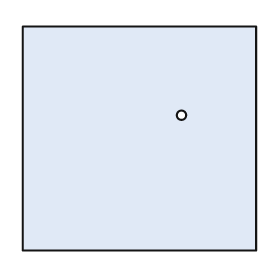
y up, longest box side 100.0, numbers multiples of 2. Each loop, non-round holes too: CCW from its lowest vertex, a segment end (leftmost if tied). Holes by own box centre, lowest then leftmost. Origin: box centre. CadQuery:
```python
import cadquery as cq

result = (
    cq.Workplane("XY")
    .moveTo(-50.0, -48.0)
    .lineTo(50.0, -48.0)
    .lineTo(50.0, 48.0)
    .lineTo(-50.0, 48.0)
    .close()
    .moveTo(18.0, 10.0)
    .circle(2.0)
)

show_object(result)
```